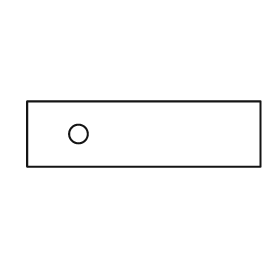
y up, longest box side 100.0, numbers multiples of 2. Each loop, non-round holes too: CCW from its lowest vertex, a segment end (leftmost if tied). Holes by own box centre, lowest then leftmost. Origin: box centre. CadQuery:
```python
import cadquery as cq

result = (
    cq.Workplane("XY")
    .moveTo(-50.0, -14.0)
    .lineTo(50.0, -14.0)
    .lineTo(50.0, 14.0)
    .lineTo(-50.0, 14.0)
    .close()
    .moveTo(-28.0, 0.0)
    .circle(4.0)
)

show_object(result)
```